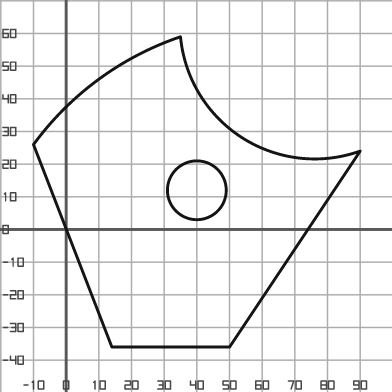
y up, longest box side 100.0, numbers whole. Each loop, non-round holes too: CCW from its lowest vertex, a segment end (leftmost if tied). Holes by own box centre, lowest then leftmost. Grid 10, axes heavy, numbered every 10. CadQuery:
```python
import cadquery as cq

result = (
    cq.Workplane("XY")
    .moveTo(14.0, -36.0)
    .lineTo(50.0, -36.0)
    .lineTo(90.0, 24.0)
    .threePointArc((54.0, 28.0), (35.0, 59.0))
    .threePointArc((10.0, 46.0), (-10.0, 26.0))
    .close()
    .moveTo(40.0, 12.0)
    .circle(9.0)
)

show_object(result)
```